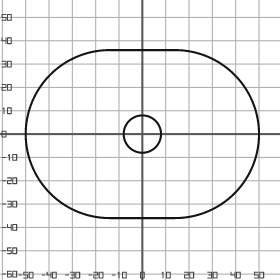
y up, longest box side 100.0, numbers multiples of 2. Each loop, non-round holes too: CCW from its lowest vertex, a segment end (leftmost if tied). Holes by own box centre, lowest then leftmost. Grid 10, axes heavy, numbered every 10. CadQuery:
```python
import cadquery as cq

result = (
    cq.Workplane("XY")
    .moveTo(-14.0, -36.0)
    .lineTo(14.0, -36.0)
    .threePointArc((50.0, 0.0), (14.0, 36.0))
    .lineTo(-14.0, 36.0)
    .threePointArc((-50.0, 0.0), (-14.0, -36.0))
    .close()
    .moveTo(0.0, 0.0)
    .circle(8.0)
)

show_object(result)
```